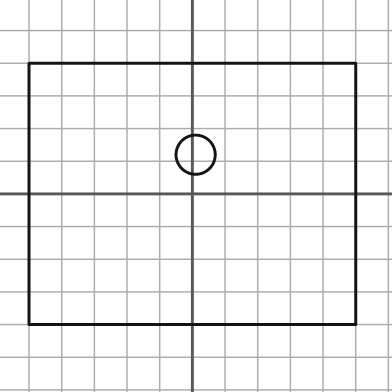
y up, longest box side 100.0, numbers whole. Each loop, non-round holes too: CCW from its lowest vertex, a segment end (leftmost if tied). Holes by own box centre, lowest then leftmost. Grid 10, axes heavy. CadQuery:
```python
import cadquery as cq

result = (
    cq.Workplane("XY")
    .moveTo(-50.0, -40.0)
    .lineTo(50.0, -40.0)
    .lineTo(50.0, 40.0)
    .lineTo(-50.0, 40.0)
    .close()
    .moveTo(1.0, 12.0)
    .circle(6.0)
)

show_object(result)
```